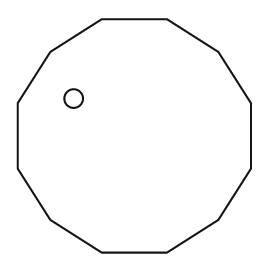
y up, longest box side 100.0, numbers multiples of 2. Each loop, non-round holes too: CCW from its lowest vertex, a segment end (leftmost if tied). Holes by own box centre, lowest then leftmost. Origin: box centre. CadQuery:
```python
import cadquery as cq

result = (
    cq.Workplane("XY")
    .moveTo(-14.0, -50.0)
    .lineTo(14.0, -50.0)
    .lineTo(36.0, -36.0)
    .lineTo(50.0, -14.0)
    .lineTo(50.0, 14.0)
    .lineTo(36.0, 36.0)
    .lineTo(14.0, 50.0)
    .lineTo(-14.0, 50.0)
    .lineTo(-36.0, 36.0)
    .lineTo(-50.0, 14.0)
    .lineTo(-50.0, -14.0)
    .lineTo(-36.0, -36.0)
    .close()
    .moveTo(-26.0, 16.0)
    .circle(4.0)
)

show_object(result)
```